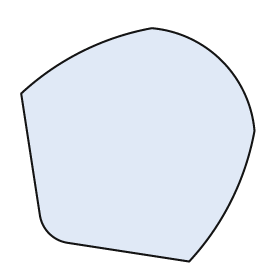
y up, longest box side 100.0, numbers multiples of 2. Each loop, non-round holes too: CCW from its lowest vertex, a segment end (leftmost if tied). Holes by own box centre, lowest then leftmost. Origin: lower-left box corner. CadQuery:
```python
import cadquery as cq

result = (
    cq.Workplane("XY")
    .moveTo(72.0, 0.0)
    .threePointArc((90.0, 26.0), (100.0, 56.0))
    .threePointArc((86.0, 86.0), (56.0, 100.0))
    .threePointArc((26.0, 90.0), (0.0, 72.0))
    .lineTo(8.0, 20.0)
    .threePointArc((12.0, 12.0), (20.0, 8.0))
    .close()
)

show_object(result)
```